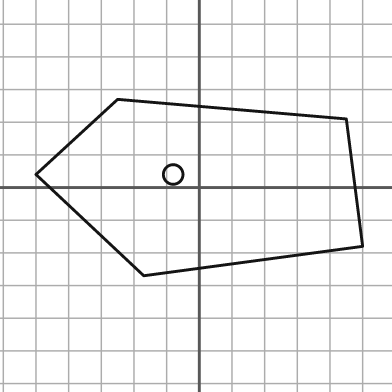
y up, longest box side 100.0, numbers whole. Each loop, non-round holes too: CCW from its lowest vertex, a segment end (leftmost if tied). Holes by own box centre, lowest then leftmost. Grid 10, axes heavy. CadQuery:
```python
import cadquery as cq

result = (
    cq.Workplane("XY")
    .moveTo(-17.0, -27.0)
    .lineTo(50.0, -18.0)
    .lineTo(45.0, 21.0)
    .lineTo(-25.0, 27.0)
    .lineTo(-50.0, 4.0)
    .close()
    .moveTo(-8.0, 4.0)
    .circle(3.0)
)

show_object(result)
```